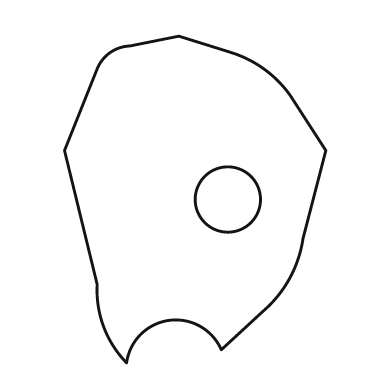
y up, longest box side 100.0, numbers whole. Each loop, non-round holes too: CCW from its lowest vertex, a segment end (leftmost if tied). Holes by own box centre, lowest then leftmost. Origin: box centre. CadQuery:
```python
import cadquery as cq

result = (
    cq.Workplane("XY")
    .moveTo(-21.0, -50.0)
    .threePointArc((-8.0, -37.0), (8.0, -46.0))
    .lineTo(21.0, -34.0)
    .threePointArc((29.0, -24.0), (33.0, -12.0))
    .lineTo(40.0, 15.0)
    .lineTo(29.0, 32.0)
    .threePointArc((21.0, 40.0), (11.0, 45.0))
    .lineTo(-5.0, 50.0)
    .lineTo(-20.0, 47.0)
    .threePointArc((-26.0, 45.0), (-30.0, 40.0))
    .lineTo(-40.0, 15.0)
    .lineTo(-30.0, -26.0)
    .threePointArc((-28.0, -39.0), (-21.0, -50.0))
    .close()
    .moveTo(10.0, 0.0)
    .circle(10.0)
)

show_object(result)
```